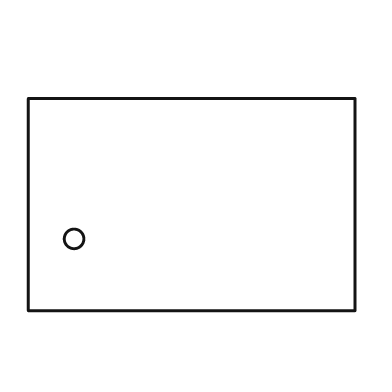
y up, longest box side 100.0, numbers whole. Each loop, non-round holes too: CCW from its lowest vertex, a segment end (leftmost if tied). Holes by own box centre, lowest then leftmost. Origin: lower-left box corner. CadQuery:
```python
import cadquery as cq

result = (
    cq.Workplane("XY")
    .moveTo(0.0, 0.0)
    .lineTo(100.0, 0.0)
    .lineTo(100.0, 65.0)
    .lineTo(0.0, 65.0)
    .close()
    .moveTo(14.0, 22.0)
    .circle(3.0)
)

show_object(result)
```